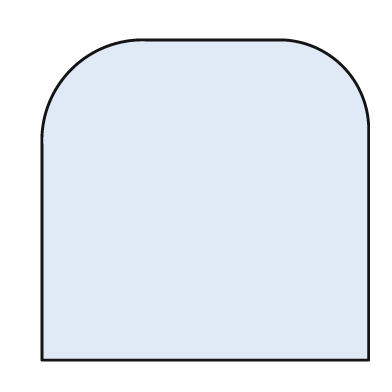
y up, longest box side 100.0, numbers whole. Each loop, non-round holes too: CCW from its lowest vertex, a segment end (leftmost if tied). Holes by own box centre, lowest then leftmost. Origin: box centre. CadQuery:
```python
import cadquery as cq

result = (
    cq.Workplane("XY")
    .moveTo(-50.0, -49.0)
    .lineTo(50.0, -49.0)
    .lineTo(50.0, 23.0)
    .threePointArc((42.0, 41.0), (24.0, 49.0))
    .lineTo(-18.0, 49.0)
    .threePointArc((-41.0, 40.0), (-50.0, 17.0))
    .close()
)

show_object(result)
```